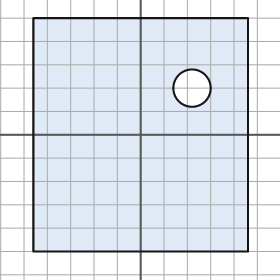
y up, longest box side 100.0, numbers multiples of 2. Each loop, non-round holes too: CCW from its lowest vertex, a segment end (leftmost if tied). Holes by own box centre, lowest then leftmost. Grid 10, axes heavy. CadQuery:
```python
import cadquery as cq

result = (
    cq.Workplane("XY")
    .moveTo(-46.0, -50.0)
    .lineTo(46.0, -50.0)
    .lineTo(46.0, 50.0)
    .lineTo(-46.0, 50.0)
    .close()
    .moveTo(22.0, 20.0)
    .circle(8.0)
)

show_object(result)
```